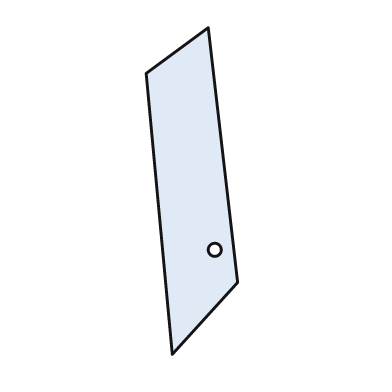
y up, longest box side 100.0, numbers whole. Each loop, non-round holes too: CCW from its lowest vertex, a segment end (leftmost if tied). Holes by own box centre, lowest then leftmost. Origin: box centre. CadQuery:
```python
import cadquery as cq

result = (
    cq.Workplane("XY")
    .moveTo(-6.0, -50.0)
    .lineTo(14.0, -28.0)
    .lineTo(5.0, 50.0)
    .lineTo(-14.0, 36.0)
    .close()
    .moveTo(7.0, -18.0)
    .circle(2.0)
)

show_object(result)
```